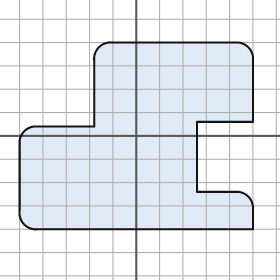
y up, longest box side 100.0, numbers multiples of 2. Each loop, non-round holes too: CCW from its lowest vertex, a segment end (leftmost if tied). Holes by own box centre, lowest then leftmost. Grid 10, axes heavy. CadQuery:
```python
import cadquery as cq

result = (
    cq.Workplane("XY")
    .moveTo(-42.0, -40.0)
    .lineTo(50.0, -40.0)
    .lineTo(50.0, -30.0)
    .threePointArc((48.0, -26.0), (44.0, -24.0))
    .lineTo(26.0, -24.0)
    .lineTo(26.0, 6.0)
    .lineTo(50.0, 6.0)
    .lineTo(50.0, 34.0)
    .threePointArc((48.0, 38.0), (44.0, 40.0))
    .lineTo(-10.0, 40.0)
    .threePointArc((-16.0, 38.0), (-18.0, 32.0))
    .lineTo(-18.0, 4.0)
    .lineTo(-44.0, 4.0)
    .threePointArc((-48.0, 2.0), (-50.0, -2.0))
    .lineTo(-50.0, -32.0)
    .threePointArc((-48.0, -38.0), (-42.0, -40.0))
    .close()
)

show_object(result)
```